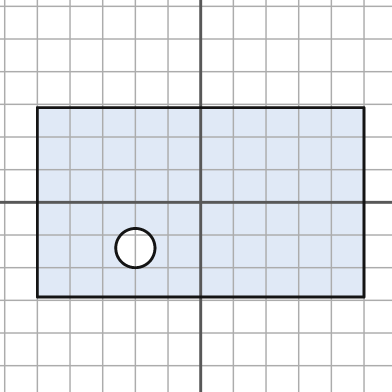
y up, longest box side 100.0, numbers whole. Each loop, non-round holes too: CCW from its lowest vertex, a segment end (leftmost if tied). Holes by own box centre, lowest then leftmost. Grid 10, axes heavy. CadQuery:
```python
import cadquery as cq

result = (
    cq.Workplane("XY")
    .moveTo(-50.0, -29.0)
    .lineTo(50.0, -29.0)
    .lineTo(50.0, 29.0)
    .lineTo(-50.0, 29.0)
    .close()
    .moveTo(-20.0, -14.0)
    .circle(6.0)
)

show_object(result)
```